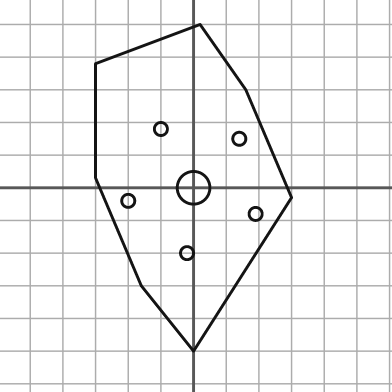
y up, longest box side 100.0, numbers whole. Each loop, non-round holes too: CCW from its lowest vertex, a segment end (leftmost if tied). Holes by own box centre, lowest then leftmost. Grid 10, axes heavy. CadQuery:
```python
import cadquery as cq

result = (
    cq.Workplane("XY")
    .moveTo(0.0, -50.0)
    .lineTo(30.0, -3.0)
    .lineTo(16.0, 30.0)
    .lineTo(2.0, 50.0)
    .lineTo(-30.0, 38.0)
    .lineTo(-30.0, 3.0)
    .lineTo(-16.0, -30.0)
    .close()
    .moveTo(-2.0, -20.0)
    .circle(2.0)
    .moveTo(19.0, -8.0)
    .circle(2.0)
    .moveTo(-20.0, -4.0)
    .circle(2.0)
    .moveTo(0.0, 0.0)
    .circle(5.0)
    .moveTo(14.0, 15.0)
    .circle(2.0)
    .moveTo(-10.0, 18.0)
    .circle(2.0)
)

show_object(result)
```